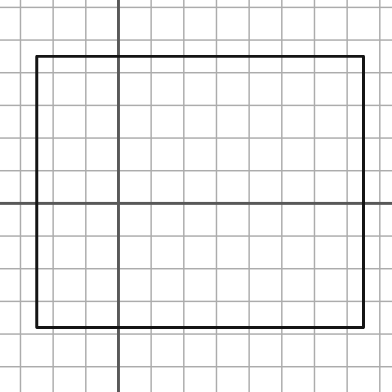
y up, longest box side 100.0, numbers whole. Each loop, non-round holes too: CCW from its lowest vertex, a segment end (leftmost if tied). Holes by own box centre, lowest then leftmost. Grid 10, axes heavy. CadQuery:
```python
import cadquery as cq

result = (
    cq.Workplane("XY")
    .moveTo(-25.0, -38.0)
    .lineTo(75.0, -38.0)
    .lineTo(75.0, 45.0)
    .lineTo(-25.0, 45.0)
    .close()
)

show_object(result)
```